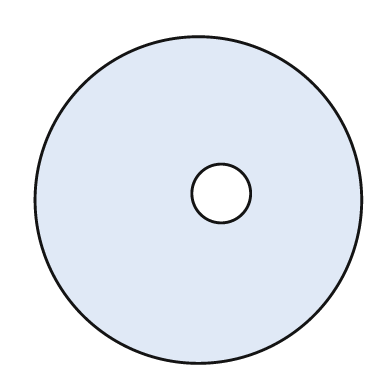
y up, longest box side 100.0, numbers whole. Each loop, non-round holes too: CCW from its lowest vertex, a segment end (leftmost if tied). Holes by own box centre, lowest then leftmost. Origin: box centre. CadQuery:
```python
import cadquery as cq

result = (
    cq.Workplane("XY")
    .moveTo(0.0, 0.0)
    .circle(50.0)
    .moveTo(7.0, 2.0)
    .circle(9.0)
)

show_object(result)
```